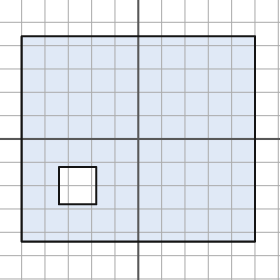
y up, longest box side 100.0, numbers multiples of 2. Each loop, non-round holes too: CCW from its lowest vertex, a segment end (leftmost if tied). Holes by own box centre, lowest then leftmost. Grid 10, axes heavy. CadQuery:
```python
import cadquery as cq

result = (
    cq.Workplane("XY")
    .moveTo(-50.0, -44.0)
    .lineTo(50.0, -44.0)
    .lineTo(50.0, 44.0)
    .lineTo(-50.0, 44.0)
    .close()
    .moveTo(-34.0, -28.0)
    .lineTo(-18.0, -28.0)
    .lineTo(-18.0, -12.0)
    .lineTo(-34.0, -12.0)
    .close()
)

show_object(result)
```